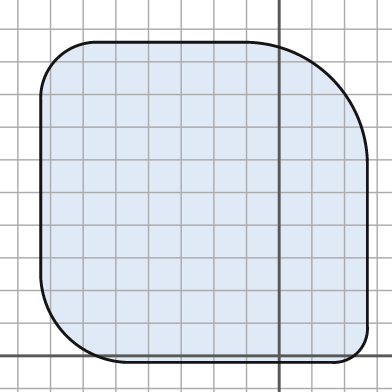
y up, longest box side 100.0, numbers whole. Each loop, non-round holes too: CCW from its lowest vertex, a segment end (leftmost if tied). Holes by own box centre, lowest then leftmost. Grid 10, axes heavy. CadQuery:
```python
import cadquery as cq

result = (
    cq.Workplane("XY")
    .moveTo(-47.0, -2.0)
    .lineTo(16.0, -2.0)
    .threePointArc((24.0, 1.0), (27.0, 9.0))
    .lineTo(27.0, 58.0)
    .threePointArc((16.0, 85.0), (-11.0, 96.0))
    .lineTo(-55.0, 96.0)
    .threePointArc((-68.0, 91.0), (-73.0, 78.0))
    .lineTo(-73.0, 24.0)
    .threePointArc((-65.0, 6.0), (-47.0, -2.0))
    .close()
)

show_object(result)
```